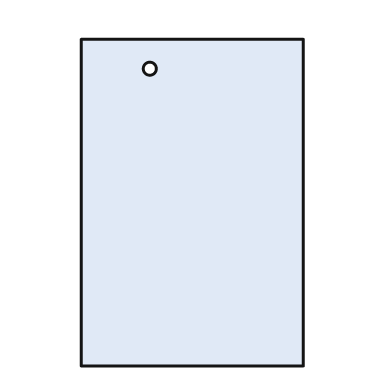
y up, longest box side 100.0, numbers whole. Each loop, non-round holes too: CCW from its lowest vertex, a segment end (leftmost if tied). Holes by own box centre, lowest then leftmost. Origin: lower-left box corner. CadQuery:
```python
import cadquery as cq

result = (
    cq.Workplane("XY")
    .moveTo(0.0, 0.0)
    .lineTo(68.0, 0.0)
    .lineTo(68.0, 100.0)
    .lineTo(0.0, 100.0)
    .close()
    .moveTo(21.0, 91.0)
    .circle(2.0)
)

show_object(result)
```